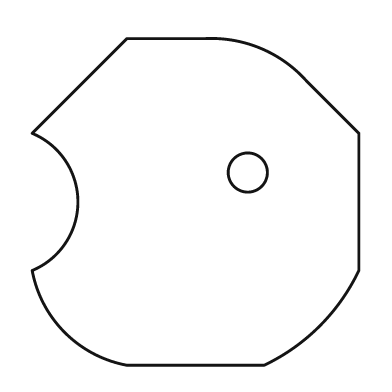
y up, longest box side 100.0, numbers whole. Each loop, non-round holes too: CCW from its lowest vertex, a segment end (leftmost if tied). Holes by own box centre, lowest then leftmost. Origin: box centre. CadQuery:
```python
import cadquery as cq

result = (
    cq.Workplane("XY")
    .moveTo(-21.0, -50.0)
    .lineTo(21.0, -50.0)
    .threePointArc((38.0, -38.0), (50.0, -21.0))
    .lineTo(50.0, 21.0)
    .lineTo(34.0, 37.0)
    .threePointArc((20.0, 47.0), (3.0, 50.0))
    .lineTo(-21.0, 50.0)
    .lineTo(-50.0, 21.0)
    .threePointArc((-36.0, 0.0), (-50.0, -21.0))
    .threePointArc((-40.0, -40.0), (-21.0, -50.0))
    .close()
    .moveTo(16.0, 9.0)
    .circle(6.0)
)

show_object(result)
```